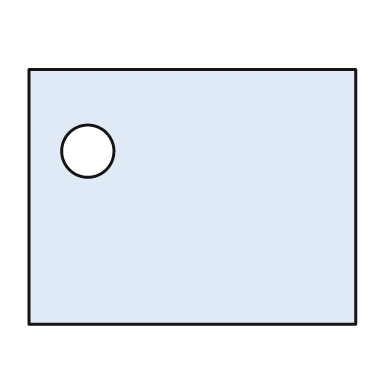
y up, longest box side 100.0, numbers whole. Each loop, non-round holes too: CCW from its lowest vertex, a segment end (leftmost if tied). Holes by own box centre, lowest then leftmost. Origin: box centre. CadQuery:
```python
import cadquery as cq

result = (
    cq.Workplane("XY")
    .moveTo(-50.0, -39.0)
    .lineTo(50.0, -39.0)
    .lineTo(50.0, 39.0)
    .lineTo(-50.0, 39.0)
    .close()
    .moveTo(-32.0, 14.0)
    .circle(8.0)
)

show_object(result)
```